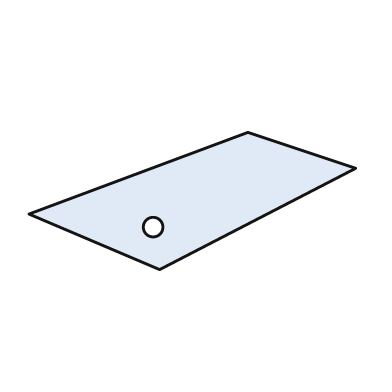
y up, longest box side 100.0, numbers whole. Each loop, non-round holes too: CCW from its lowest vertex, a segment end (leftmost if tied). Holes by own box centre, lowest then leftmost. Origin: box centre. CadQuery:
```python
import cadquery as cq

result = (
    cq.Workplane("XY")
    .moveTo(-10.0, -21.0)
    .lineTo(50.0, 10.0)
    .lineTo(17.0, 21.0)
    .lineTo(-50.0, -4.0)
    .close()
    .moveTo(-12.0, -8.0)
    .circle(3.0)
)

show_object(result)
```